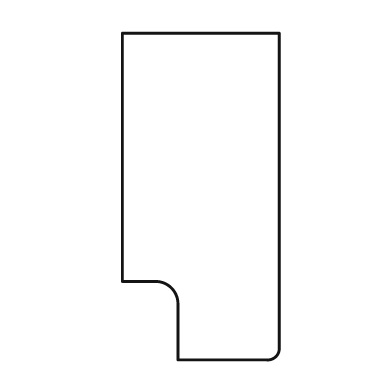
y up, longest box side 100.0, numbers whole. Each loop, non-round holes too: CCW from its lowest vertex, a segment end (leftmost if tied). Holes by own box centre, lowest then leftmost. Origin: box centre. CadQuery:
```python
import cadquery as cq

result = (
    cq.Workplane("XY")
    .moveTo(-7.0, -50.0)
    .lineTo(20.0, -50.0)
    .threePointArc((23.0, -49.0), (24.0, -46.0))
    .lineTo(24.0, 50.0)
    .lineTo(-24.0, 50.0)
    .lineTo(-24.0, -26.0)
    .lineTo(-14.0, -26.0)
    .threePointArc((-9.0, -28.0), (-7.0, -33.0))
    .close()
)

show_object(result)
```